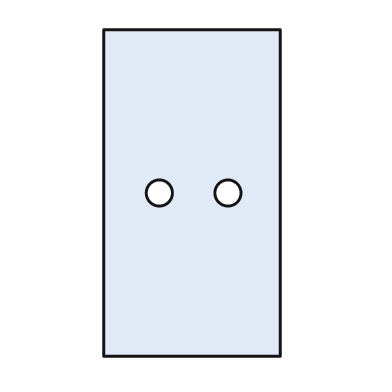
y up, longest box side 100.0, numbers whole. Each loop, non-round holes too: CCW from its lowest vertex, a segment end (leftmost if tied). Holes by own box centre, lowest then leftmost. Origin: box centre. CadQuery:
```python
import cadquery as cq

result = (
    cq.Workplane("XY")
    .moveTo(-27.0, -50.0)
    .lineTo(27.0, -50.0)
    .lineTo(27.0, 50.0)
    .lineTo(-27.0, 50.0)
    .close()
    .moveTo(-10.0, 0.0)
    .circle(4.0)
    .moveTo(11.0, 0.0)
    .circle(4.0)
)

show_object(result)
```